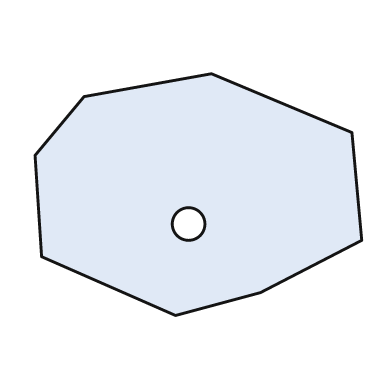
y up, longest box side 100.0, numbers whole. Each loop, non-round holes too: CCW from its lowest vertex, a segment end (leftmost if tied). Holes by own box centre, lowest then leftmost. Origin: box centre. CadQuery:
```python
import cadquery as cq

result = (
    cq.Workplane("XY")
    .moveTo(-7.0, -37.0)
    .lineTo(19.0, -30.0)
    .lineTo(50.0, -14.0)
    .lineTo(47.0, 19.0)
    .lineTo(4.0, 37.0)
    .lineTo(-35.0, 30.0)
    .lineTo(-50.0, 12.0)
    .lineTo(-48.0, -19.0)
    .close()
    .moveTo(-3.0, -9.0)
    .circle(5.0)
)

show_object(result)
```